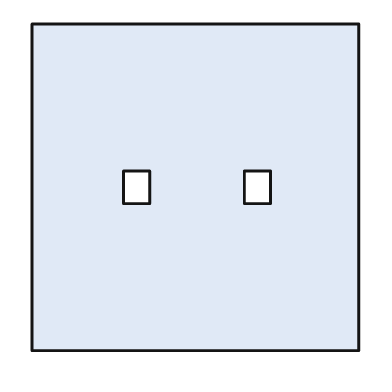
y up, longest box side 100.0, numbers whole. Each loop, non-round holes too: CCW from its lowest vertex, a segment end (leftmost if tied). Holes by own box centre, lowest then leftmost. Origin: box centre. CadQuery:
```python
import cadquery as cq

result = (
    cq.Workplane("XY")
    .moveTo(-50.0, -50.0)
    .lineTo(50.0, -50.0)
    .lineTo(50.0, 50.0)
    .lineTo(-50.0, 50.0)
    .close()
    .moveTo(-22.0, -5.0)
    .lineTo(-14.0, -5.0)
    .lineTo(-14.0, 5.0)
    .lineTo(-22.0, 5.0)
    .close()
    .moveTo(15.0, -5.0)
    .lineTo(23.0, -5.0)
    .lineTo(23.0, 5.0)
    .lineTo(15.0, 5.0)
    .close()
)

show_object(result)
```